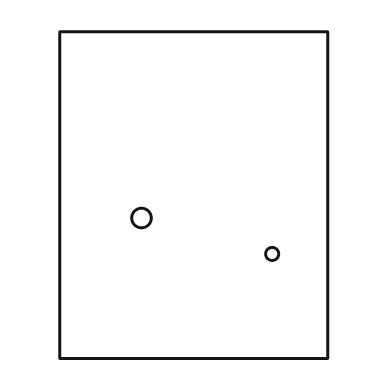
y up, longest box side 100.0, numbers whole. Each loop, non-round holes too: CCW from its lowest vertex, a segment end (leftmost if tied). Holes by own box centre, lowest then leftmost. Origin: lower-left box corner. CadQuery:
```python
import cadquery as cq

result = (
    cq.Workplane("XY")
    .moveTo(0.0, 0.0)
    .lineTo(82.0, 0.0)
    .lineTo(82.0, 100.0)
    .lineTo(0.0, 100.0)
    .close()
    .moveTo(65.0, 32.0)
    .circle(2.0)
    .moveTo(25.0, 43.0)
    .circle(3.0)
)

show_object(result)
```